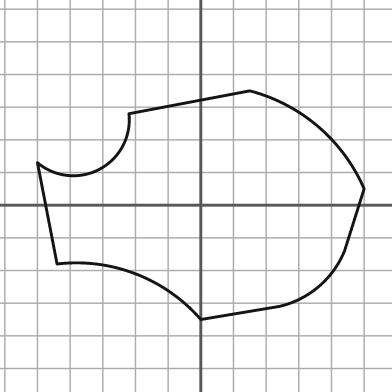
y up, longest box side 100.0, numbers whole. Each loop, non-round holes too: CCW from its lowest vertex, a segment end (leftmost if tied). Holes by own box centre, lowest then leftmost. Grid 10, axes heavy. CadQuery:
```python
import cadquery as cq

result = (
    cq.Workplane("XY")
    .moveTo(0.0, -35.0)
    .lineTo(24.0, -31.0)
    .threePointArc((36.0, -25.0), (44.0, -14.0))
    .lineTo(50.0, 5.0)
    .threePointArc((36.0, 24.0), (15.0, 35.0))
    .lineTo(-22.0, 28.0)
    .threePointArc((-31.0, 11.0), (-50.0, 13.0))
    .lineTo(-44.0, -18.0)
    .threePointArc((-20.0, -21.0), (0.0, -35.0))
    .close()
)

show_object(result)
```